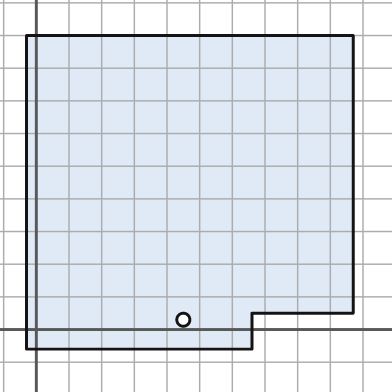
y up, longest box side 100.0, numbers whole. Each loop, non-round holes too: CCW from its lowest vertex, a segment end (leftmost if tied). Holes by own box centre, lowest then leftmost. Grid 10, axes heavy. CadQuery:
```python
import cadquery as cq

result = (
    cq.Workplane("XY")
    .moveTo(-3.0, -6.0)
    .lineTo(66.0, -6.0)
    .lineTo(66.0, 5.0)
    .lineTo(97.0, 5.0)
    .lineTo(97.0, 90.0)
    .lineTo(-3.0, 90.0)
    .close()
    .moveTo(45.0, 3.0)
    .circle(2.0)
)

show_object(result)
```